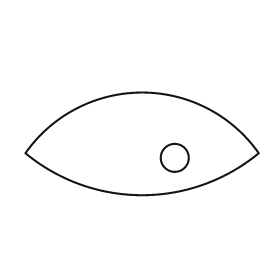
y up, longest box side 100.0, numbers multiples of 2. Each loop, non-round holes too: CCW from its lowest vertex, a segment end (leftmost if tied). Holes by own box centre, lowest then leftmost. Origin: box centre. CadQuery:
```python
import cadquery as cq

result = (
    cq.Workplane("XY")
    .moveTo(-50.0, -4.0)
    .threePointArc((0.0, -22.0), (50.0, -4.0))
    .threePointArc((0.0, 22.0), (-50.0, -4.0))
    .close()
    .moveTo(14.0, -6.0)
    .circle(6.0)
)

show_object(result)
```